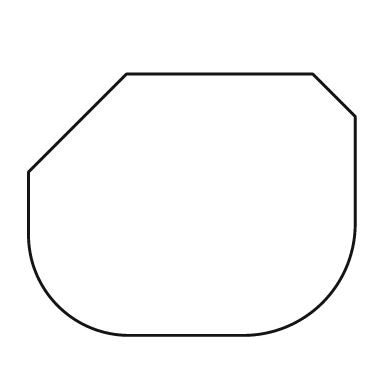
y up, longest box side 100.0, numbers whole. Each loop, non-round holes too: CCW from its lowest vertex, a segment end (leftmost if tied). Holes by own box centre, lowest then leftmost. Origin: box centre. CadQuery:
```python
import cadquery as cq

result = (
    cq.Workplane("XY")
    .moveTo(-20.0, -40.0)
    .lineTo(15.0, -40.0)
    .threePointArc((40.0, -30.0), (50.0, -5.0))
    .lineTo(50.0, 27.0)
    .lineTo(37.0, 40.0)
    .lineTo(-20.0, 40.0)
    .lineTo(-50.0, 10.0)
    .lineTo(-50.0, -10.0)
    .threePointArc((-41.0, -31.0), (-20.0, -40.0))
    .close()
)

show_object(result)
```